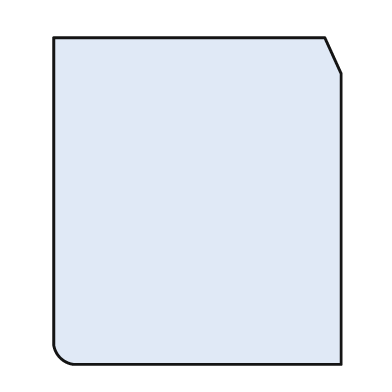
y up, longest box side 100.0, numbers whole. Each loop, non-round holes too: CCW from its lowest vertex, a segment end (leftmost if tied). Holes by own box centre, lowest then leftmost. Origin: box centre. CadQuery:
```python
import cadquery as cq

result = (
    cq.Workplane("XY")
    .moveTo(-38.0, -50.0)
    .lineTo(44.0, -50.0)
    .lineTo(44.0, 39.0)
    .lineTo(39.0, 50.0)
    .lineTo(-44.0, 50.0)
    .lineTo(-44.0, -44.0)
    .threePointArc((-42.0, -48.0), (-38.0, -50.0))
    .close()
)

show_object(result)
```